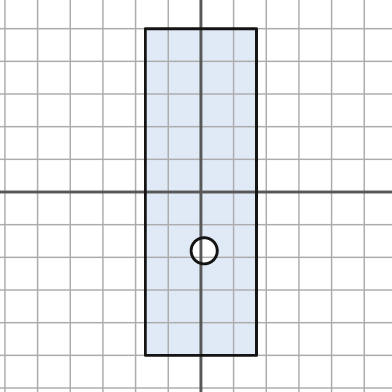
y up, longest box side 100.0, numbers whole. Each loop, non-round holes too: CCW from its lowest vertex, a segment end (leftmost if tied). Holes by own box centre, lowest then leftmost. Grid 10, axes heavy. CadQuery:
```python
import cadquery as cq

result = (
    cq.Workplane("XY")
    .moveTo(-17.0, -50.0)
    .lineTo(17.0, -50.0)
    .lineTo(17.0, 50.0)
    .lineTo(-17.0, 50.0)
    .close()
    .moveTo(1.0, -18.0)
    .circle(4.0)
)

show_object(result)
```